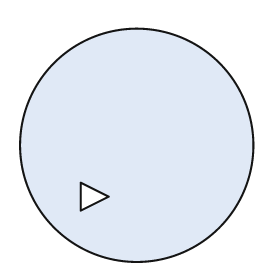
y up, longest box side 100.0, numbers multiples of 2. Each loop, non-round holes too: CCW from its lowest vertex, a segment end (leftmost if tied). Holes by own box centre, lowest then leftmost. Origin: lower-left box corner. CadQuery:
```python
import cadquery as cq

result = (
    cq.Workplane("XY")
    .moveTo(50.0, 50.0)
    .circle(50.0)
    .moveTo(26.0, 22.0)
    .lineTo(38.0, 28.0)
    .lineTo(26.0, 34.0)
    .close()
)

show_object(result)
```